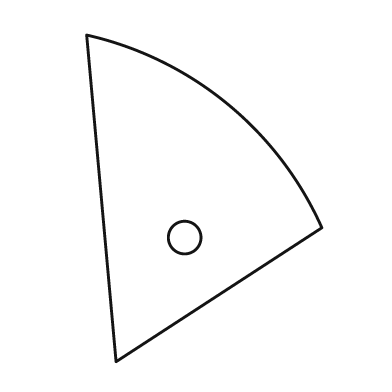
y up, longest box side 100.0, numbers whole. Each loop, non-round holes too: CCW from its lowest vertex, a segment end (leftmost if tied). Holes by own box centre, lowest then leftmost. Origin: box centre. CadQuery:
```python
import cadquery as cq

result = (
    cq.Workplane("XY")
    .moveTo(-27.0, -50.0)
    .lineTo(36.0, -9.0)
    .threePointArc((7.0, 29.0), (-36.0, 50.0))
    .close()
    .moveTo(-6.0, -12.0)
    .circle(5.0)
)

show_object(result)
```